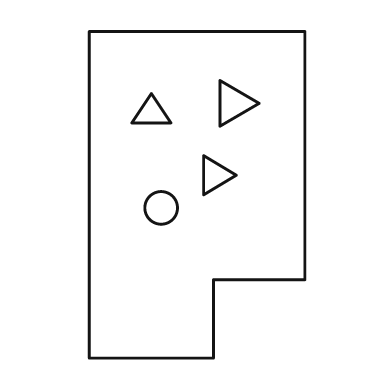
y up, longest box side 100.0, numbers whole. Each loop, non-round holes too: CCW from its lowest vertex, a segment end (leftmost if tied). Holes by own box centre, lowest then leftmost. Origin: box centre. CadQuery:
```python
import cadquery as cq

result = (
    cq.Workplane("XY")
    .moveTo(-33.0, -50.0)
    .lineTo(5.0, -50.0)
    .lineTo(5.0, -26.0)
    .lineTo(33.0, -26.0)
    .lineTo(33.0, 50.0)
    .lineTo(-33.0, 50.0)
    .close()
    .moveTo(-11.0, -4.0)
    .circle(5.0)
    .moveTo(2.0, 0.0)
    .lineTo(12.0, 6.0)
    .lineTo(2.0, 12.0)
    .close()
    .moveTo(-20.0, 22.0)
    .lineTo(-8.0, 22.0)
    .lineTo(-14.0, 31.0)
    .close()
    .moveTo(7.0, 21.0)
    .lineTo(19.0, 28.0)
    .lineTo(7.0, 35.0)
    .close()
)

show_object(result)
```